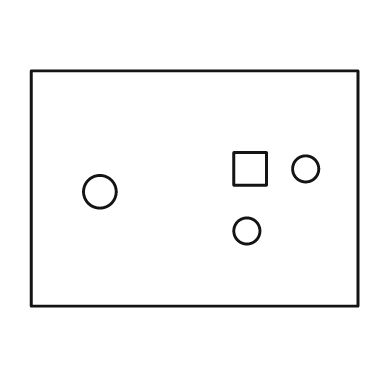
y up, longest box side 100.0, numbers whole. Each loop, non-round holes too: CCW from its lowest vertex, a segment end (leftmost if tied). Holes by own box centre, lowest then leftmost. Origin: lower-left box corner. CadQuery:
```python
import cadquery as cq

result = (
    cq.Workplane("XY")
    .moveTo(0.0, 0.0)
    .lineTo(100.0, 0.0)
    .lineTo(100.0, 72.0)
    .lineTo(0.0, 72.0)
    .close()
    .moveTo(66.0, 23.0)
    .circle(4.0)
    .moveTo(21.0, 35.0)
    .circle(5.0)
    .moveTo(62.0, 37.0)
    .lineTo(72.0, 37.0)
    .lineTo(72.0, 47.0)
    .lineTo(62.0, 47.0)
    .close()
    .moveTo(84.0, 42.0)
    .circle(4.0)
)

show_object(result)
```